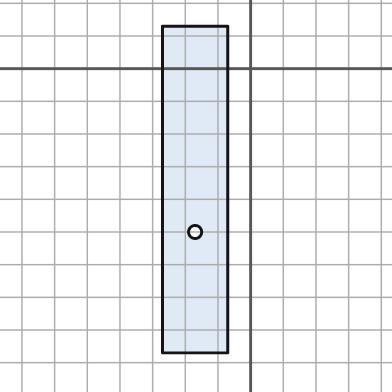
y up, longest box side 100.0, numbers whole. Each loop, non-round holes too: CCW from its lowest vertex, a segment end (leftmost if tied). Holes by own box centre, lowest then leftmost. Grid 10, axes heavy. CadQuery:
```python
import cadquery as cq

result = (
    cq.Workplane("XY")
    .moveTo(-27.0, -87.0)
    .lineTo(-7.0, -87.0)
    .lineTo(-7.0, 13.0)
    .lineTo(-27.0, 13.0)
    .close()
    .moveTo(-17.0, -50.0)
    .circle(2.0)
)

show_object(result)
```